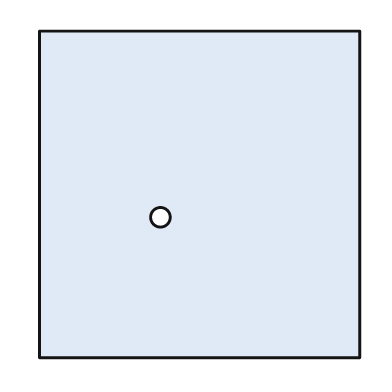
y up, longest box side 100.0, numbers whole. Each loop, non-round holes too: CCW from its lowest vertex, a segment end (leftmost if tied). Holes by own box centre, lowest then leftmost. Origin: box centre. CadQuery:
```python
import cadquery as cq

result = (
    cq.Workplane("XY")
    .moveTo(-49.0, -50.0)
    .lineTo(49.0, -50.0)
    .lineTo(49.0, 50.0)
    .lineTo(-49.0, 50.0)
    .close()
    .moveTo(-12.0, -7.0)
    .circle(3.0)
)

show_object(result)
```